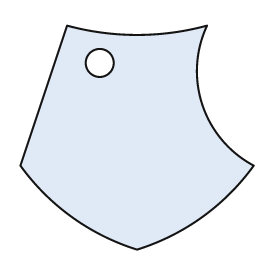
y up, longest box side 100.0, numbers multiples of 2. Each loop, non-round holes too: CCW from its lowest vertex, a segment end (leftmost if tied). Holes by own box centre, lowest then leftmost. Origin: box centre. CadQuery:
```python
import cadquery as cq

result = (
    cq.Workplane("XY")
    .moveTo(0.0, -48.0)
    .threePointArc((28.0, -34.0), (50.0, -12.0))
    .threePointArc((28.0, 14.0), (30.0, 48.0))
    .threePointArc((0.0, 44.0), (-30.0, 48.0))
    .lineTo(-50.0, -12.0)
    .threePointArc((-28.0, -34.0), (0.0, -48.0))
    .close()
    .moveTo(-16.0, 32.0)
    .circle(6.0)
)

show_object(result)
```